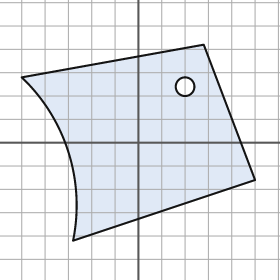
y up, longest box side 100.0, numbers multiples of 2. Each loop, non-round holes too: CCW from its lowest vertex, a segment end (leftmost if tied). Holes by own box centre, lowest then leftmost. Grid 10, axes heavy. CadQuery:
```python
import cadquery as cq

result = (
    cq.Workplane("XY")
    .moveTo(-28.0, -42.0)
    .lineTo(50.0, -16.0)
    .lineTo(28.0, 42.0)
    .lineTo(-50.0, 28.0)
    .threePointArc((-30.0, -4.0), (-28.0, -42.0))
    .close()
    .moveTo(20.0, 24.0)
    .circle(4.0)
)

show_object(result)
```